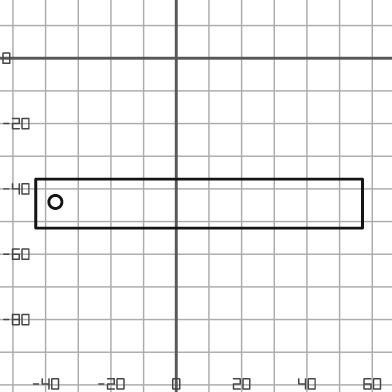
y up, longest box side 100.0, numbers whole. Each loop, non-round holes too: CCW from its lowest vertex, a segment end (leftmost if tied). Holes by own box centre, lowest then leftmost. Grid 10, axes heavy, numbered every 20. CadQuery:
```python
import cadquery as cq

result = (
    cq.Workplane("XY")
    .moveTo(-43.0, -52.0)
    .lineTo(57.0, -52.0)
    .lineTo(57.0, -37.0)
    .lineTo(-43.0, -37.0)
    .close()
    .moveTo(-37.0, -44.0)
    .circle(2.0)
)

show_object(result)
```